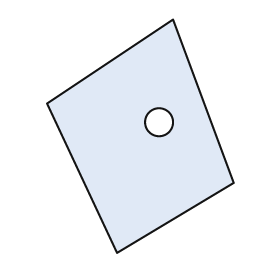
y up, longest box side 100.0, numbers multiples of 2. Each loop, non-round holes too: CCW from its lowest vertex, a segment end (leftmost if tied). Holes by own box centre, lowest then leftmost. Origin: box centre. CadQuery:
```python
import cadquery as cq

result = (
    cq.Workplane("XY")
    .moveTo(-10.0, -50.0)
    .lineTo(40.0, -20.0)
    .lineTo(14.0, 50.0)
    .lineTo(-40.0, 14.0)
    .close()
    .moveTo(8.0, 6.0)
    .circle(6.0)
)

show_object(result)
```